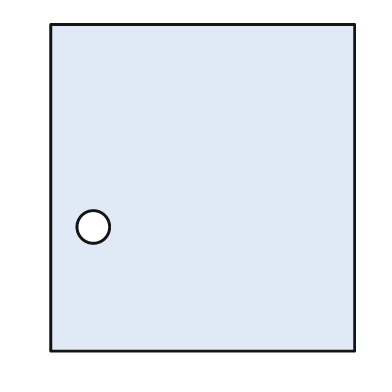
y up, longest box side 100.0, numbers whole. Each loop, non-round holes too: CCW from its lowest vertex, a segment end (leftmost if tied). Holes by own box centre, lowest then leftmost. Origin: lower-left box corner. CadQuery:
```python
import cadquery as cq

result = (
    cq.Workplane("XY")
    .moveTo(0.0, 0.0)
    .lineTo(93.0, 0.0)
    .lineTo(93.0, 100.0)
    .lineTo(0.0, 100.0)
    .close()
    .moveTo(13.0, 38.0)
    .circle(5.0)
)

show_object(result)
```